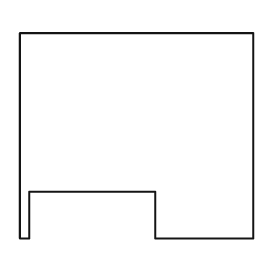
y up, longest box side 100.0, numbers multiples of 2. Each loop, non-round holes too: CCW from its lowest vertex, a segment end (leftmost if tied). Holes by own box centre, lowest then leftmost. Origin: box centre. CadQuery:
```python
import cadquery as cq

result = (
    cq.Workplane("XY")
    .moveTo(-50.0, -44.0)
    .lineTo(-46.0, -44.0)
    .lineTo(-46.0, -24.0)
    .lineTo(8.0, -24.0)
    .lineTo(8.0, -44.0)
    .lineTo(50.0, -44.0)
    .lineTo(50.0, 44.0)
    .lineTo(-50.0, 44.0)
    .close()
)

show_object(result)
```